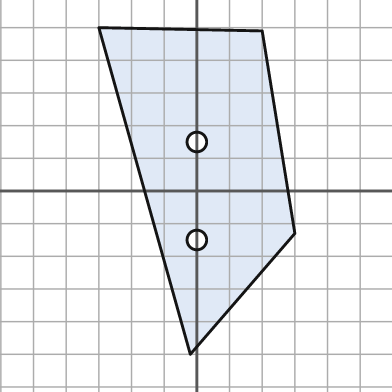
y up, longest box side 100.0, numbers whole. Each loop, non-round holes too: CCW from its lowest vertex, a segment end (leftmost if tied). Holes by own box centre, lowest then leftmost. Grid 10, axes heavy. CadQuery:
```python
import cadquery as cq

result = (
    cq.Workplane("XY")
    .moveTo(-2.0, -50.0)
    .lineTo(30.0, -13.0)
    .lineTo(20.0, 49.0)
    .lineTo(-30.0, 50.0)
    .close()
    .moveTo(0.0, -15.0)
    .circle(3.0)
    .moveTo(0.0, 15.0)
    .circle(3.0)
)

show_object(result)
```